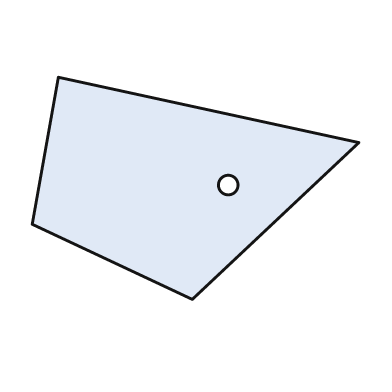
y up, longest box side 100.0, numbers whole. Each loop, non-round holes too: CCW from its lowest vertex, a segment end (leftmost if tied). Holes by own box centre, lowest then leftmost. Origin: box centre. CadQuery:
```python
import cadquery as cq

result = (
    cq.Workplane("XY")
    .moveTo(-1.0, -34.0)
    .lineTo(50.0, 14.0)
    .lineTo(-42.0, 34.0)
    .lineTo(-50.0, -11.0)
    .close()
    .moveTo(10.0, 1.0)
    .circle(3.0)
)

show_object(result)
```